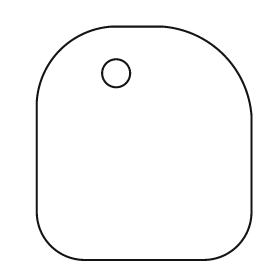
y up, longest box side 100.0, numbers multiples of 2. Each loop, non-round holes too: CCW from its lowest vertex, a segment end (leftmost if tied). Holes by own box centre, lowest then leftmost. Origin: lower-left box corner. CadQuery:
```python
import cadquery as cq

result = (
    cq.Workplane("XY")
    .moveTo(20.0, 0.0)
    .lineTo(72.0, 0.0)
    .threePointArc((86.0, 6.0), (92.0, 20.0))
    .lineTo(92.0, 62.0)
    .threePointArc((80.0, 88.0), (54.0, 100.0))
    .lineTo(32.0, 100.0)
    .threePointArc((10.0, 90.0), (0.0, 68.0))
    .lineTo(0.0, 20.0)
    .threePointArc((6.0, 6.0), (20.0, 0.0))
    .close()
    .moveTo(34.0, 80.0)
    .circle(6.0)
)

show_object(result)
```